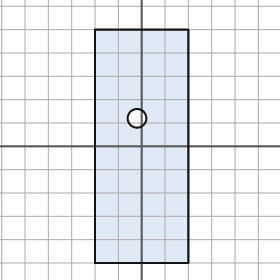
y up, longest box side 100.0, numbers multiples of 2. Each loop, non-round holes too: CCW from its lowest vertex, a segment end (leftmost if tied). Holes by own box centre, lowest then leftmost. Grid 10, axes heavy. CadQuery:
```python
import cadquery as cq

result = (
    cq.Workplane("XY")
    .moveTo(-20.0, -50.0)
    .lineTo(20.0, -50.0)
    .lineTo(20.0, 50.0)
    .lineTo(-20.0, 50.0)
    .close()
    .moveTo(-2.0, 12.0)
    .circle(4.0)
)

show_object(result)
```